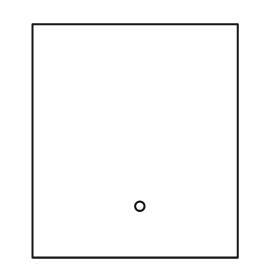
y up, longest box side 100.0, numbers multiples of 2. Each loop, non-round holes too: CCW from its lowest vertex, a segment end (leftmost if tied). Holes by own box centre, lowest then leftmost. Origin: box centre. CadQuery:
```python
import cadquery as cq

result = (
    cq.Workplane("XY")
    .moveTo(-44.0, -50.0)
    .lineTo(44.0, -50.0)
    .lineTo(44.0, 50.0)
    .lineTo(-44.0, 50.0)
    .close()
    .moveTo(2.0, -28.0)
    .circle(2.0)
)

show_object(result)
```